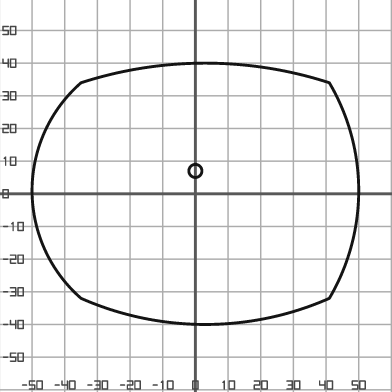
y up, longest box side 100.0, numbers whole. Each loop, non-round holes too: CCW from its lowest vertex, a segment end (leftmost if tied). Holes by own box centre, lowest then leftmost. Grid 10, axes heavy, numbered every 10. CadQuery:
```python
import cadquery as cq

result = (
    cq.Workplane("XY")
    .moveTo(-35.0, -32.0)
    .threePointArc((3.0, -40.0), (41.0, -32.0))
    .threePointArc((50.0, 1.0), (41.0, 34.0))
    .threePointArc((3.0, 40.0), (-35.0, 34.0))
    .threePointArc((-50.0, 1.0), (-35.0, -32.0))
    .close()
    .moveTo(0.0, 7.0)
    .circle(2.0)
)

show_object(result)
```